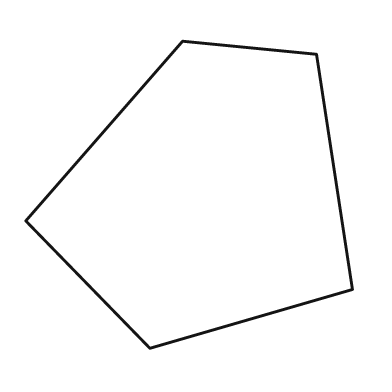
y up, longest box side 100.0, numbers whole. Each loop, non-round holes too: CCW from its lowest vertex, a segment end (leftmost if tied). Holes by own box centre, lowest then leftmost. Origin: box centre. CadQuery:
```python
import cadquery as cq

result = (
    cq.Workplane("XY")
    .moveTo(-12.0, -47.0)
    .lineTo(50.0, -29.0)
    .lineTo(39.0, 43.0)
    .lineTo(-2.0, 47.0)
    .lineTo(-50.0, -8.0)
    .close()
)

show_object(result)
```